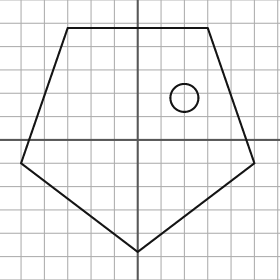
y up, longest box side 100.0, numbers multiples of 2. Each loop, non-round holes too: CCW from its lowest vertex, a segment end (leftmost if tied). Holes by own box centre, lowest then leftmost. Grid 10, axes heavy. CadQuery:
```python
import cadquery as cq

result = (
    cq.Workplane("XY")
    .moveTo(0.0, -48.0)
    .lineTo(50.0, -10.0)
    .lineTo(30.0, 48.0)
    .lineTo(-30.0, 48.0)
    .lineTo(-50.0, -10.0)
    .close()
    .moveTo(20.0, 18.0)
    .circle(6.0)
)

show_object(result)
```